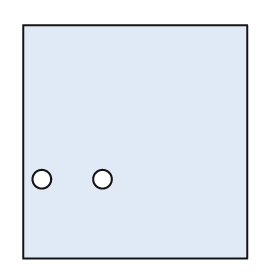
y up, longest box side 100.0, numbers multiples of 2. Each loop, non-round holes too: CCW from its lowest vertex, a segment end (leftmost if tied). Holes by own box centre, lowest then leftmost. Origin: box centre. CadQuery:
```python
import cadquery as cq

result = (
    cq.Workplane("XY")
    .moveTo(-48.0, -50.0)
    .lineTo(48.0, -50.0)
    .lineTo(48.0, 50.0)
    .lineTo(-48.0, 50.0)
    .close()
    .moveTo(-40.0, -16.0)
    .circle(4.0)
    .moveTo(-14.0, -16.0)
    .circle(4.0)
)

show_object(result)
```